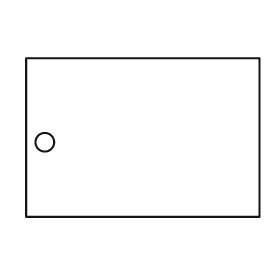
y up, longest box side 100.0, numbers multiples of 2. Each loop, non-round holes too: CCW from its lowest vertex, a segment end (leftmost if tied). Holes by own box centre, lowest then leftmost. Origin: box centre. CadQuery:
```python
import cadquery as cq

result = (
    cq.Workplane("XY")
    .moveTo(-50.0, -34.0)
    .lineTo(50.0, -34.0)
    .lineTo(50.0, 34.0)
    .lineTo(-50.0, 34.0)
    .close()
    .moveTo(-42.0, -2.0)
    .circle(4.0)
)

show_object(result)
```